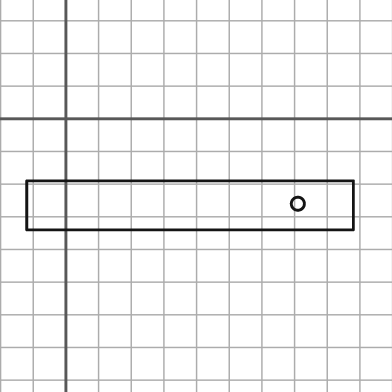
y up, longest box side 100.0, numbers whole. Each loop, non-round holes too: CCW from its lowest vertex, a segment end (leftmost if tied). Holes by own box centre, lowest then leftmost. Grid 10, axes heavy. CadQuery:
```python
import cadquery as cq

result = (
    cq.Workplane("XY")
    .moveTo(-12.0, -34.0)
    .lineTo(88.0, -34.0)
    .lineTo(88.0, -19.0)
    .lineTo(-12.0, -19.0)
    .close()
    .moveTo(71.0, -26.0)
    .circle(2.0)
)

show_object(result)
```